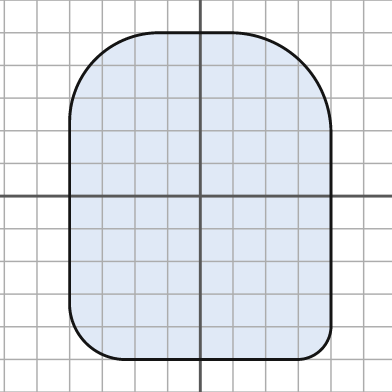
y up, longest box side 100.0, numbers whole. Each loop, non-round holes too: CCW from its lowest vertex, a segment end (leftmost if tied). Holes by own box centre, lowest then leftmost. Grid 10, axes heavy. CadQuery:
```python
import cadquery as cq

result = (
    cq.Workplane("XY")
    .moveTo(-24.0, -50.0)
    .lineTo(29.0, -50.0)
    .threePointArc((37.0, -47.0), (40.0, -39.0))
    .lineTo(40.0, 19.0)
    .threePointArc((31.0, 41.0), (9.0, 50.0))
    .lineTo(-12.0, 50.0)
    .threePointArc((-32.0, 42.0), (-40.0, 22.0))
    .lineTo(-40.0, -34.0)
    .threePointArc((-35.0, -45.0), (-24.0, -50.0))
    .close()
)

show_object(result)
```